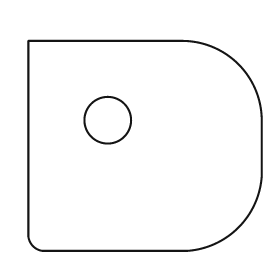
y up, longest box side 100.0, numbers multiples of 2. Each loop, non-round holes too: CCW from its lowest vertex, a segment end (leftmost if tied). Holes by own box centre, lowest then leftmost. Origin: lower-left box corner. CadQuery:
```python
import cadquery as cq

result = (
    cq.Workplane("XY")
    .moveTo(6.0, 0.0)
    .lineTo(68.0, 0.0)
    .threePointArc((90.0, 10.0), (100.0, 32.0))
    .lineTo(100.0, 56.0)
    .threePointArc((90.0, 80.0), (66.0, 90.0))
    .lineTo(0.0, 90.0)
    .lineTo(0.0, 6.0)
    .threePointArc((2.0, 2.0), (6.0, 0.0))
    .close()
    .moveTo(34.0, 56.0)
    .circle(10.0)
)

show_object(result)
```